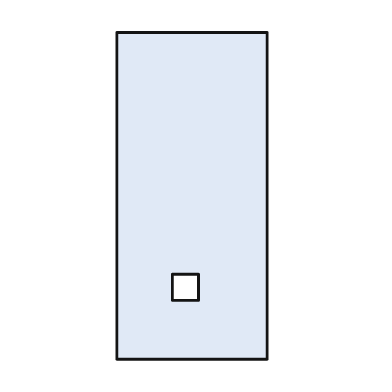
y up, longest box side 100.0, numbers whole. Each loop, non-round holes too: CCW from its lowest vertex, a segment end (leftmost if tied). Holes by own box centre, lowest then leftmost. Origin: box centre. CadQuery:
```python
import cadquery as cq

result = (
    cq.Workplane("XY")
    .moveTo(-23.0, -50.0)
    .lineTo(23.0, -50.0)
    .lineTo(23.0, 50.0)
    .lineTo(-23.0, 50.0)
    .close()
    .moveTo(-6.0, -32.0)
    .lineTo(2.0, -32.0)
    .lineTo(2.0, -24.0)
    .lineTo(-6.0, -24.0)
    .close()
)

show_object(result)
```